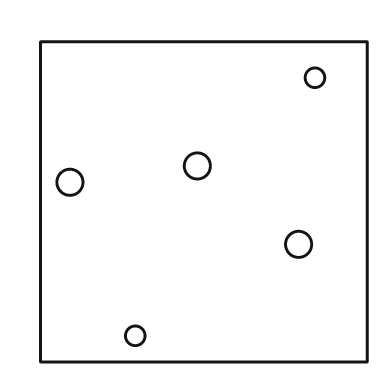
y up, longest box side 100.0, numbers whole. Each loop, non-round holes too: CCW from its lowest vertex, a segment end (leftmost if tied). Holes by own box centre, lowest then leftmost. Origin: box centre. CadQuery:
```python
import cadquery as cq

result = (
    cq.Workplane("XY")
    .moveTo(-50.0, -49.0)
    .lineTo(50.0, -49.0)
    .lineTo(50.0, 49.0)
    .lineTo(-50.0, 49.0)
    .close()
    .moveTo(-21.0, -41.0)
    .circle(3.0)
    .moveTo(29.0, -13.0)
    .circle(4.0)
    .moveTo(-41.0, 6.0)
    .circle(4.0)
    .moveTo(-2.0, 11.0)
    .circle(4.0)
    .moveTo(34.0, 38.0)
    .circle(3.0)
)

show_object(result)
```